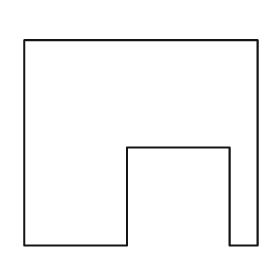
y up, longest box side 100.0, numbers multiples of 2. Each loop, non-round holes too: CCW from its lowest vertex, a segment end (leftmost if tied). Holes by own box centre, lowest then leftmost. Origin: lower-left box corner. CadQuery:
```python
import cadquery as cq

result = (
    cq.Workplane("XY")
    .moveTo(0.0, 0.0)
    .lineTo(44.0, 0.0)
    .lineTo(44.0, 42.0)
    .lineTo(88.0, 42.0)
    .lineTo(88.0, 0.0)
    .lineTo(100.0, 0.0)
    .lineTo(100.0, 88.0)
    .lineTo(0.0, 88.0)
    .close()
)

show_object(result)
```